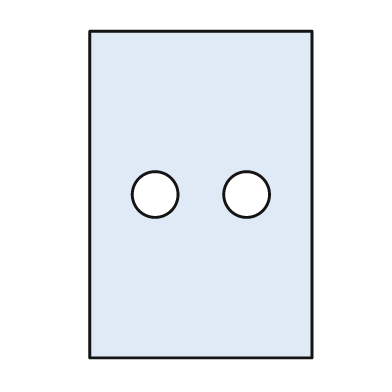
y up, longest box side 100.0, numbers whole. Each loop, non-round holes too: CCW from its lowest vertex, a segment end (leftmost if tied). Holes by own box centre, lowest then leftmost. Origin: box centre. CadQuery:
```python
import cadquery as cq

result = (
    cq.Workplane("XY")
    .moveTo(-34.0, -50.0)
    .lineTo(34.0, -50.0)
    .lineTo(34.0, 50.0)
    .lineTo(-34.0, 50.0)
    .close()
    .moveTo(-14.0, 0.0)
    .circle(7.0)
    .moveTo(14.0, 0.0)
    .circle(7.0)
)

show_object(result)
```